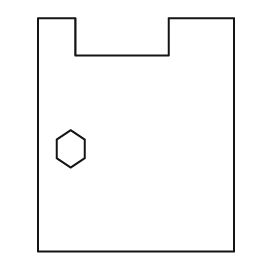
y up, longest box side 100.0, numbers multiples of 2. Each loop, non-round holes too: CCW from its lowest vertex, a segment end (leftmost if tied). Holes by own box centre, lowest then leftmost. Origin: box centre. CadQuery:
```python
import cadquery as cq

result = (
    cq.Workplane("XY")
    .moveTo(-42.0, -50.0)
    .lineTo(42.0, -50.0)
    .lineTo(42.0, 50.0)
    .lineTo(14.0, 50.0)
    .lineTo(14.0, 34.0)
    .lineTo(-26.0, 34.0)
    .lineTo(-26.0, 50.0)
    .lineTo(-42.0, 50.0)
    .close()
    .moveTo(-28.0, -14.0)
    .lineTo(-22.0, -10.0)
    .lineTo(-22.0, -2.0)
    .lineTo(-28.0, 2.0)
    .lineTo(-34.0, -2.0)
    .lineTo(-34.0, -10.0)
    .close()
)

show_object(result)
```